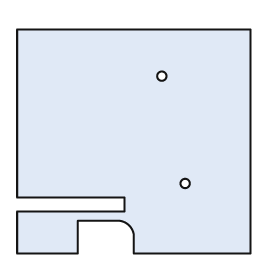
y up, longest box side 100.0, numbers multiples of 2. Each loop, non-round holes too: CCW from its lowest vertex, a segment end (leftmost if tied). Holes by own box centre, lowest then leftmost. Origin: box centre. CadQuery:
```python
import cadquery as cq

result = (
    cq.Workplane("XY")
    .moveTo(-50.0, -48.0)
    .lineTo(-24.0, -48.0)
    .lineTo(-24.0, -34.0)
    .lineTo(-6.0, -34.0)
    .threePointArc((-2.0, -36.0), (0.0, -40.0))
    .lineTo(0.0, -48.0)
    .lineTo(50.0, -48.0)
    .lineTo(50.0, 48.0)
    .lineTo(-50.0, 48.0)
    .lineTo(-50.0, -24.0)
    .lineTo(-4.0, -24.0)
    .lineTo(-4.0, -30.0)
    .lineTo(-50.0, -30.0)
    .close()
    .moveTo(22.0, -18.0)
    .circle(2.0)
    .moveTo(12.0, 28.0)
    .circle(2.0)
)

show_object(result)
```